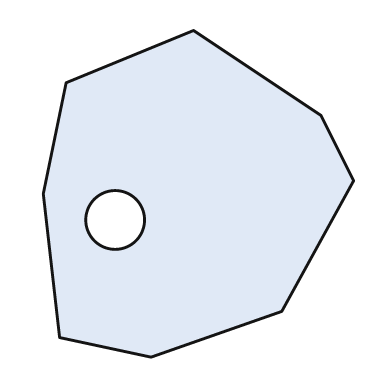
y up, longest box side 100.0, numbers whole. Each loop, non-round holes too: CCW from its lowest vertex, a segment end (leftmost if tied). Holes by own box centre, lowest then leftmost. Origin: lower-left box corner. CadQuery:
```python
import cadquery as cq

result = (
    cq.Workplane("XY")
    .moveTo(33.0, 0.0)
    .lineTo(73.0, 14.0)
    .lineTo(95.0, 54.0)
    .lineTo(85.0, 74.0)
    .lineTo(46.0, 100.0)
    .lineTo(7.0, 84.0)
    .lineTo(0.0, 50.0)
    .lineTo(5.0, 6.0)
    .close()
    .moveTo(22.0, 42.0)
    .circle(9.0)
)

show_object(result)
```